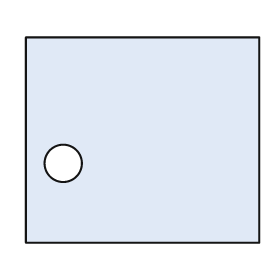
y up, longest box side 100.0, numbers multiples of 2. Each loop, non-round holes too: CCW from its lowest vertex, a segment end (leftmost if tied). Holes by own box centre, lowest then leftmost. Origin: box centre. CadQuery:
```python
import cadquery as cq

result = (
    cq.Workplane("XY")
    .moveTo(-50.0, -44.0)
    .lineTo(50.0, -44.0)
    .lineTo(50.0, 44.0)
    .lineTo(-50.0, 44.0)
    .close()
    .moveTo(-34.0, -10.0)
    .circle(8.0)
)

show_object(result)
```